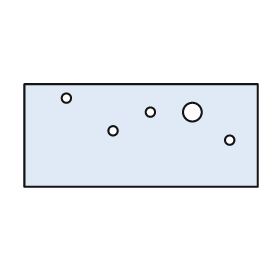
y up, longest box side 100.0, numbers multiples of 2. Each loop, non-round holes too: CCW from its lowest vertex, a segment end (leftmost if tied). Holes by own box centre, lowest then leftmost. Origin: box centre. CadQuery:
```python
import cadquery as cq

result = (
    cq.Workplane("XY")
    .moveTo(-50.0, -22.0)
    .lineTo(50.0, -22.0)
    .lineTo(50.0, 22.0)
    .lineTo(-50.0, 22.0)
    .close()
    .moveTo(38.0, -2.0)
    .circle(2.0)
    .moveTo(-12.0, 2.0)
    .circle(2.0)
    .moveTo(4.0, 10.0)
    .circle(2.0)
    .moveTo(22.0, 10.0)
    .circle(4.0)
    .moveTo(-32.0, 16.0)
    .circle(2.0)
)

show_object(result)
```